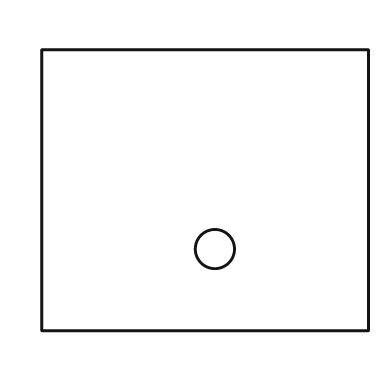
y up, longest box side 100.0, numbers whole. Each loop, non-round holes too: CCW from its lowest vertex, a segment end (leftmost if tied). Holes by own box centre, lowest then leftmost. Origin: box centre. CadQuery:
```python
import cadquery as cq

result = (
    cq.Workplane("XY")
    .moveTo(-50.0, -43.0)
    .lineTo(50.0, -43.0)
    .lineTo(50.0, 43.0)
    .lineTo(-50.0, 43.0)
    .close()
    .moveTo(3.0, -18.0)
    .circle(6.0)
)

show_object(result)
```